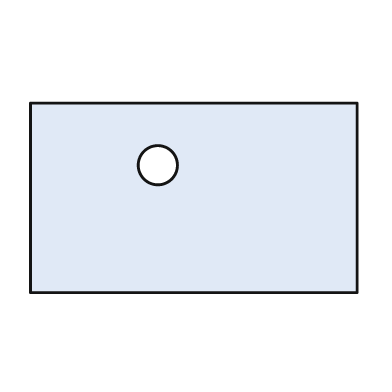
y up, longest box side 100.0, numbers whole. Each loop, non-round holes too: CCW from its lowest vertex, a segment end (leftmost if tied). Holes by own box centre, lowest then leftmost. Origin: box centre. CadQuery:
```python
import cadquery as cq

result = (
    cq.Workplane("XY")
    .moveTo(-50.0, -29.0)
    .lineTo(50.0, -29.0)
    .lineTo(50.0, 29.0)
    .lineTo(-50.0, 29.0)
    .close()
    .moveTo(-11.0, 10.0)
    .circle(6.0)
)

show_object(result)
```